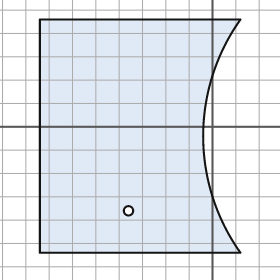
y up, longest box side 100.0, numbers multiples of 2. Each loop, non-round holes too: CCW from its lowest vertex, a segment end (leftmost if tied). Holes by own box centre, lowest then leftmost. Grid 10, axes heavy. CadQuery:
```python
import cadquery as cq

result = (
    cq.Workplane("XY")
    .moveTo(-74.0, -54.0)
    .lineTo(12.0, -54.0)
    .threePointArc((-4.0, -4.0), (12.0, 46.0))
    .lineTo(-74.0, 46.0)
    .close()
    .moveTo(-36.0, -36.0)
    .circle(2.0)
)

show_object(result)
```